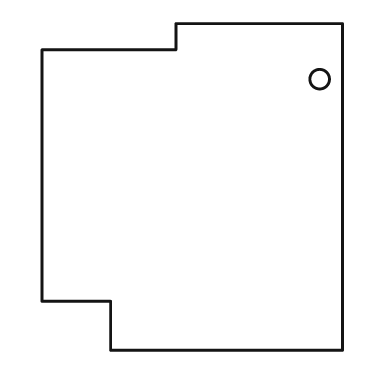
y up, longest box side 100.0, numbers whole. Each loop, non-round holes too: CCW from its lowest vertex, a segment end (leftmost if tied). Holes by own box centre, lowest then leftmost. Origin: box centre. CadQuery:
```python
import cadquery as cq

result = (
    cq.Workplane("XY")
    .moveTo(-25.0, -50.0)
    .lineTo(46.0, -50.0)
    .lineTo(46.0, 50.0)
    .lineTo(-5.0, 50.0)
    .lineTo(-5.0, 42.0)
    .lineTo(-46.0, 42.0)
    .lineTo(-46.0, -35.0)
    .lineTo(-25.0, -35.0)
    .close()
    .moveTo(39.0, 33.0)
    .circle(3.0)
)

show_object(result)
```